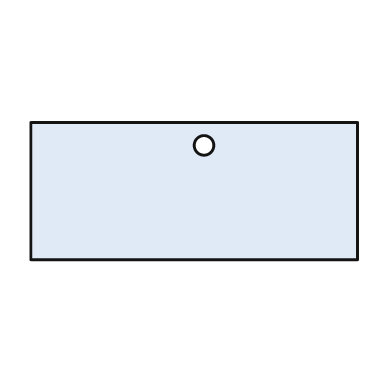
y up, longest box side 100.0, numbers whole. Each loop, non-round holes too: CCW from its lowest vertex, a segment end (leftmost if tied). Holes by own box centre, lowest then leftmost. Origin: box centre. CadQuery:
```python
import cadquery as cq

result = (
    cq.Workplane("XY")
    .moveTo(-50.0, -21.0)
    .lineTo(50.0, -21.0)
    .lineTo(50.0, 21.0)
    .lineTo(-50.0, 21.0)
    .close()
    .moveTo(3.0, 14.0)
    .circle(3.0)
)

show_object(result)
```